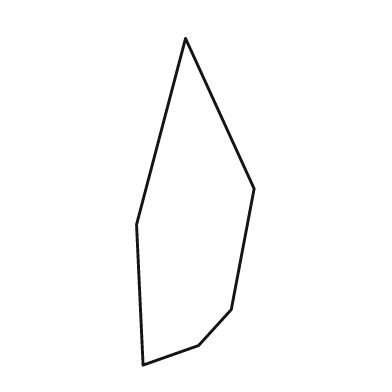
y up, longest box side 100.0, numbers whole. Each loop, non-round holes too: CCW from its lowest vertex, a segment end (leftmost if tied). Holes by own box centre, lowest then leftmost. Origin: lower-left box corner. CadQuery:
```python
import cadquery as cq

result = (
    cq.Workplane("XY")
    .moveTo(2.0, 0.0)
    .lineTo(19.0, 6.0)
    .lineTo(29.0, 17.0)
    .lineTo(36.0, 54.0)
    .lineTo(15.0, 100.0)
    .lineTo(0.0, 43.0)
    .close()
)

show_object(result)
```